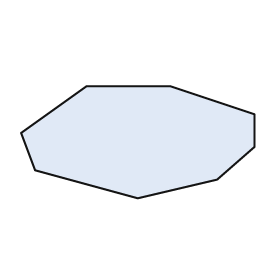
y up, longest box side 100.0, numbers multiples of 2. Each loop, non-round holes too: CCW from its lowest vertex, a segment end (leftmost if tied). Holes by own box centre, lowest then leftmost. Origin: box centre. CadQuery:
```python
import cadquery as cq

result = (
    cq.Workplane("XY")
    .moveTo(0.0, -24.0)
    .lineTo(34.0, -16.0)
    .lineTo(50.0, -2.0)
    .lineTo(50.0, 12.0)
    .lineTo(14.0, 24.0)
    .lineTo(-22.0, 24.0)
    .lineTo(-50.0, 4.0)
    .lineTo(-44.0, -12.0)
    .close()
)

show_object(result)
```